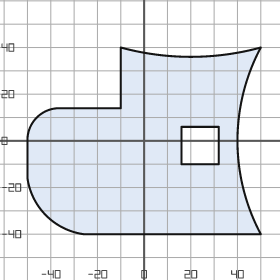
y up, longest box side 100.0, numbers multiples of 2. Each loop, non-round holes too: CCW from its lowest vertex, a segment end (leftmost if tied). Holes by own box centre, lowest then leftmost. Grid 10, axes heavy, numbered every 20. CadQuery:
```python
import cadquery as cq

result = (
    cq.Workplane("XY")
    .moveTo(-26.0, -40.0)
    .lineTo(50.0, -40.0)
    .threePointArc((40.0, 0.0), (50.0, 40.0))
    .threePointArc((20.0, 36.0), (-10.0, 40.0))
    .lineTo(-10.0, 14.0)
    .lineTo(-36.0, 14.0)
    .threePointArc((-46.0, 10.0), (-50.0, 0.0))
    .lineTo(-50.0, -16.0)
    .threePointArc((-42.0, -32.0), (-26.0, -40.0))
    .close()
    .moveTo(16.0, -10.0)
    .lineTo(32.0, -10.0)
    .lineTo(32.0, 6.0)
    .lineTo(16.0, 6.0)
    .close()
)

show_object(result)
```